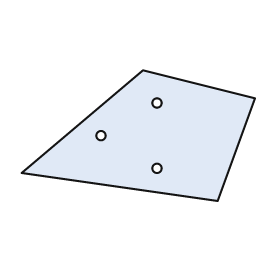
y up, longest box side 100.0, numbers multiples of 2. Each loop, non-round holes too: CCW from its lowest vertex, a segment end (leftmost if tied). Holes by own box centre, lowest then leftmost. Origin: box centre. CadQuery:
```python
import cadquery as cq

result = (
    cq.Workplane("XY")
    .moveTo(34.0, -28.0)
    .lineTo(50.0, 16.0)
    .lineTo(2.0, 28.0)
    .lineTo(-50.0, -16.0)
    .close()
    .moveTo(8.0, -14.0)
    .circle(2.0)
    .moveTo(-16.0, 0.0)
    .circle(2.0)
    .moveTo(8.0, 14.0)
    .circle(2.0)
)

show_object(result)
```